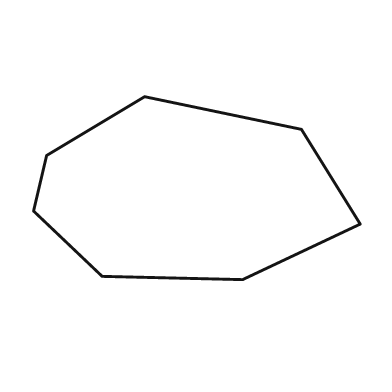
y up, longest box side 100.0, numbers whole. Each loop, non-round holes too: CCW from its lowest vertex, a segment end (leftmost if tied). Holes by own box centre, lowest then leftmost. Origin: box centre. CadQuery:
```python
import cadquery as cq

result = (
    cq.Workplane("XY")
    .moveTo(14.0, -28.0)
    .lineTo(50.0, -11.0)
    .lineTo(32.0, 18.0)
    .lineTo(-16.0, 28.0)
    .lineTo(-46.0, 10.0)
    .lineTo(-50.0, -7.0)
    .lineTo(-29.0, -27.0)
    .close()
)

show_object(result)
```